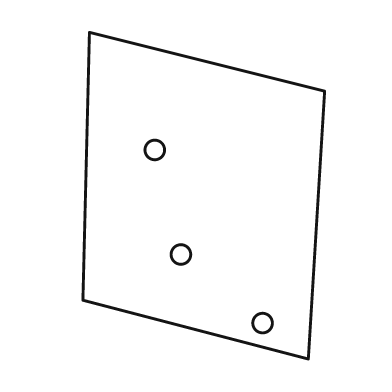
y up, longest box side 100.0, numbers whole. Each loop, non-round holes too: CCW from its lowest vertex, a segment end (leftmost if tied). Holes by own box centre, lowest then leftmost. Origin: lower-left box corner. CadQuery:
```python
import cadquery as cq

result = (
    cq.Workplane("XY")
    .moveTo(69.0, 0.0)
    .lineTo(74.0, 82.0)
    .lineTo(2.0, 100.0)
    .lineTo(0.0, 18.0)
    .close()
    .moveTo(55.0, 11.0)
    .circle(3.0)
    .moveTo(30.0, 32.0)
    .circle(3.0)
    .moveTo(22.0, 64.0)
    .circle(3.0)
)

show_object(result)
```